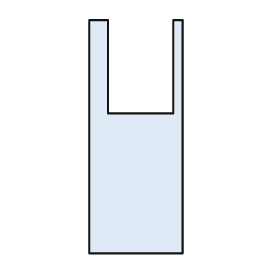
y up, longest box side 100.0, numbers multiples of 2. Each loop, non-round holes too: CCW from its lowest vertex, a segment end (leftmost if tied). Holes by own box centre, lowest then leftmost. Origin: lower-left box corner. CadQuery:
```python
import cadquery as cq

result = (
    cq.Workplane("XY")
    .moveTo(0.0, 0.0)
    .lineTo(40.0, 0.0)
    .lineTo(40.0, 100.0)
    .lineTo(36.0, 100.0)
    .lineTo(36.0, 60.0)
    .lineTo(8.0, 60.0)
    .lineTo(8.0, 100.0)
    .lineTo(0.0, 100.0)
    .close()
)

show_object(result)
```